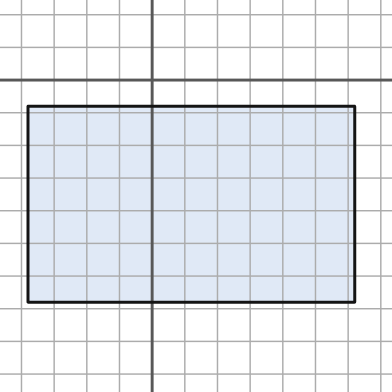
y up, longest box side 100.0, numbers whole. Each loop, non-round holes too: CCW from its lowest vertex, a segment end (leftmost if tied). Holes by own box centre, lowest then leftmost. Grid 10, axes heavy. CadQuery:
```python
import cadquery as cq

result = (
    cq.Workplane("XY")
    .moveTo(-38.0, -68.0)
    .lineTo(62.0, -68.0)
    .lineTo(62.0, -8.0)
    .lineTo(-38.0, -8.0)
    .close()
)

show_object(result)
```